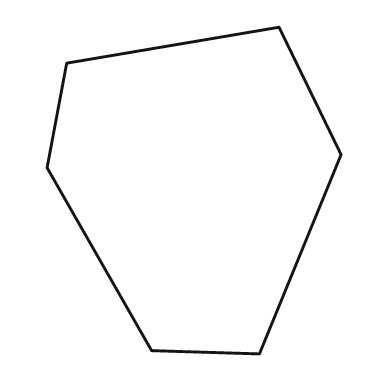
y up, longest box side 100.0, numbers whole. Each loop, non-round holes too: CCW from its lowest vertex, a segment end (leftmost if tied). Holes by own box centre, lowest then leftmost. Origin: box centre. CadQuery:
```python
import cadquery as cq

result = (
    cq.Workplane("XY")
    .moveTo(20.0, -50.0)
    .lineTo(45.0, 11.0)
    .lineTo(26.0, 50.0)
    .lineTo(-39.0, 39.0)
    .lineTo(-45.0, 7.0)
    .lineTo(-13.0, -49.0)
    .close()
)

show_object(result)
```